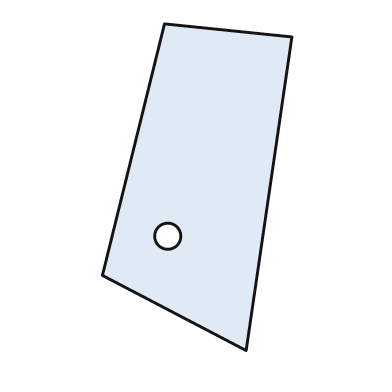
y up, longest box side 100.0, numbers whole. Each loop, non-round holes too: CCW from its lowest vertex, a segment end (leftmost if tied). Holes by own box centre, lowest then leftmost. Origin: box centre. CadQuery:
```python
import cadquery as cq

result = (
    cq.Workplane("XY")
    .moveTo(15.0, -50.0)
    .lineTo(29.0, 46.0)
    .lineTo(-10.0, 50.0)
    .lineTo(-29.0, -27.0)
    .close()
    .moveTo(-9.0, -15.0)
    .circle(4.0)
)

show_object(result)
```